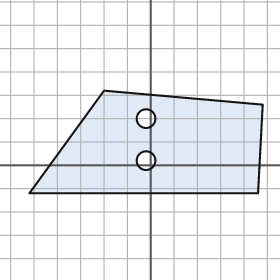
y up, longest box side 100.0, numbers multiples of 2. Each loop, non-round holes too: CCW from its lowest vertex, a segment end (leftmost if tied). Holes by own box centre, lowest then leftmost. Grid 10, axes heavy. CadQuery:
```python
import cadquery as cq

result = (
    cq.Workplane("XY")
    .moveTo(-52.0, -12.0)
    .lineTo(46.0, -12.0)
    .lineTo(48.0, 26.0)
    .lineTo(-20.0, 32.0)
    .close()
    .moveTo(-2.0, 2.0)
    .circle(4.0)
    .moveTo(-2.0, 20.0)
    .circle(4.0)
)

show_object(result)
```